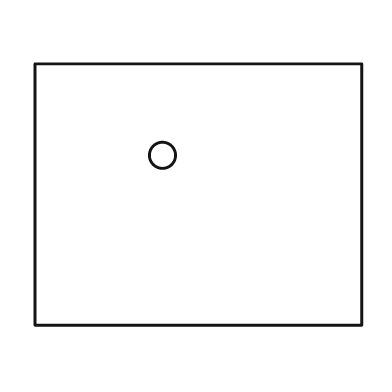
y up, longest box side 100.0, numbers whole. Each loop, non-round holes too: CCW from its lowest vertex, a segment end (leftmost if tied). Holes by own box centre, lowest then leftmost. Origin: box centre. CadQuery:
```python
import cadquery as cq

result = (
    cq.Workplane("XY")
    .moveTo(-50.0, -40.0)
    .lineTo(50.0, -40.0)
    .lineTo(50.0, 40.0)
    .lineTo(-50.0, 40.0)
    .close()
    .moveTo(-11.0, 12.0)
    .circle(4.0)
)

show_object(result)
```